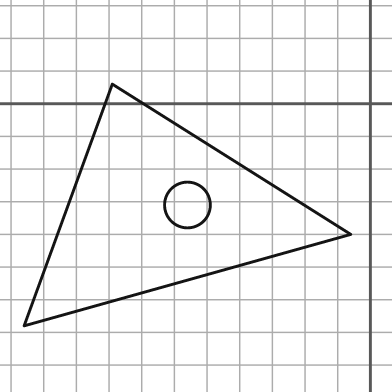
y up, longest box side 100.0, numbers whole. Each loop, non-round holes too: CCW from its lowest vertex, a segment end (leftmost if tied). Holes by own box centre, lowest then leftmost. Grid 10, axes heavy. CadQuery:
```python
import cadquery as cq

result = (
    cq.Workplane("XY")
    .moveTo(-106.0, -68.0)
    .lineTo(-6.0, -40.0)
    .lineTo(-79.0, 6.0)
    .close()
    .moveTo(-56.0, -31.0)
    .circle(7.0)
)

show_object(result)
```